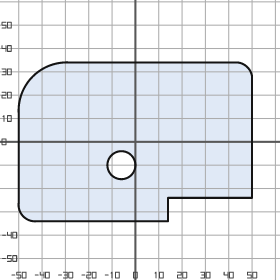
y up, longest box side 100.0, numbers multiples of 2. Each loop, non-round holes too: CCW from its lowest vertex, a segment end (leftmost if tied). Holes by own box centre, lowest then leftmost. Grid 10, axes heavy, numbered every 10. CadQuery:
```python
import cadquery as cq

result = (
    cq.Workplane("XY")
    .moveTo(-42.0, -34.0)
    .lineTo(14.0, -34.0)
    .lineTo(14.0, -24.0)
    .lineTo(50.0, -24.0)
    .lineTo(50.0, 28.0)
    .threePointArc((48.0, 32.0), (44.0, 34.0))
    .lineTo(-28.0, 34.0)
    .threePointArc((-44.0, 28.0), (-50.0, 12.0))
    .lineTo(-50.0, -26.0)
    .threePointArc((-48.0, -32.0), (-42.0, -34.0))
    .close()
    .moveTo(-6.0, -10.0)
    .circle(6.0)
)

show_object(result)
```